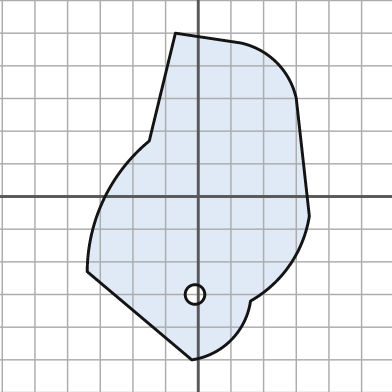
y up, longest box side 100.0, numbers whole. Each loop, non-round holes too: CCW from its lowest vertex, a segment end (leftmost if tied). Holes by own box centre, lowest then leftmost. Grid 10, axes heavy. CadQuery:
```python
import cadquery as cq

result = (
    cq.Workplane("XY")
    .moveTo(-2.0, -50.0)
    .threePointArc((10.0, -44.0), (16.0, -32.0))
    .threePointArc((28.0, -21.0), (34.0, -6.0))
    .lineTo(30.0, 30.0)
    .threePointArc((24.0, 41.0), (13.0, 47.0))
    .lineTo(-7.0, 50.0)
    .lineTo(-15.0, 17.0)
    .threePointArc((-29.0, -1.0), (-34.0, -23.0))
    .close()
    .moveTo(-1.0, -30.0)
    .circle(3.0)
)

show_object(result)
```